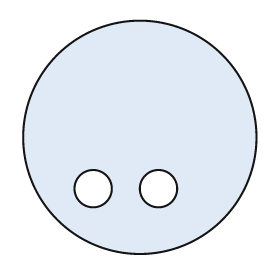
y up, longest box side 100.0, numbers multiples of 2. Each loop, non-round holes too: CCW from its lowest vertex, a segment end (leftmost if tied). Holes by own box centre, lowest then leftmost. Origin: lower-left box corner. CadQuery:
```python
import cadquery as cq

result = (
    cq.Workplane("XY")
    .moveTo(50.0, 50.0)
    .circle(50.0)
    .moveTo(30.0, 28.0)
    .circle(8.0)
    .moveTo(58.0, 28.0)
    .circle(8.0)
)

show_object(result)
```